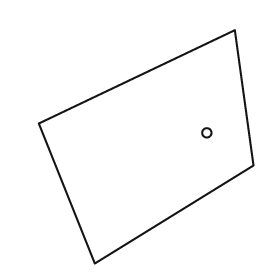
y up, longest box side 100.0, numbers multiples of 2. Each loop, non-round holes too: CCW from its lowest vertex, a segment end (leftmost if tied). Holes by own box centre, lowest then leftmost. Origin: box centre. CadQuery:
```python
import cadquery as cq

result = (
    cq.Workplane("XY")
    .moveTo(-22.0, -50.0)
    .lineTo(46.0, -8.0)
    .lineTo(38.0, 50.0)
    .lineTo(-46.0, 10.0)
    .close()
    .moveTo(26.0, 6.0)
    .circle(2.0)
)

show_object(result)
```